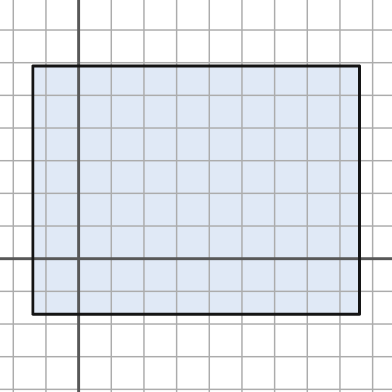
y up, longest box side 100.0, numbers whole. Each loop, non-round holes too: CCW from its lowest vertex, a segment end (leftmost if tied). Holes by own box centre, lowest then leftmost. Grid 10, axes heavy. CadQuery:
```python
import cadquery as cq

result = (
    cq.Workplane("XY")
    .moveTo(-14.0, -17.0)
    .lineTo(86.0, -17.0)
    .lineTo(86.0, 59.0)
    .lineTo(-14.0, 59.0)
    .close()
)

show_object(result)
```